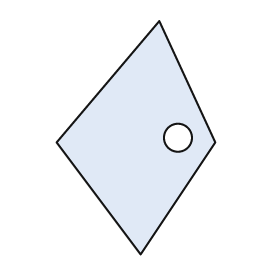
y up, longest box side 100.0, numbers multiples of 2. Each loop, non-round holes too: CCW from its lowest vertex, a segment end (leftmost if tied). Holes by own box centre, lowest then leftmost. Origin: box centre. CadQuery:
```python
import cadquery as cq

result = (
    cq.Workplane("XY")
    .moveTo(2.0, -50.0)
    .lineTo(34.0, -2.0)
    .lineTo(10.0, 50.0)
    .lineTo(-34.0, -2.0)
    .close()
    .moveTo(18.0, 0.0)
    .circle(6.0)
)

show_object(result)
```